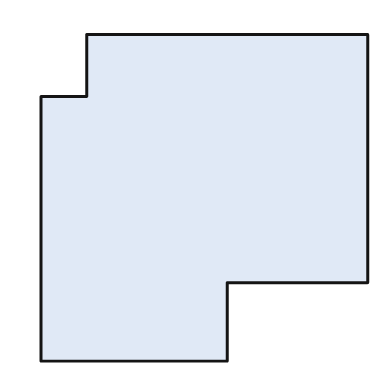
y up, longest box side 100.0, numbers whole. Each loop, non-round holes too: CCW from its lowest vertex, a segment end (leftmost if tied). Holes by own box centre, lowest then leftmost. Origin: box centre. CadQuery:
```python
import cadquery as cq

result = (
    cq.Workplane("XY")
    .moveTo(-50.0, -50.0)
    .lineTo(7.0, -50.0)
    .lineTo(7.0, -26.0)
    .lineTo(50.0, -26.0)
    .lineTo(50.0, 50.0)
    .lineTo(-36.0, 50.0)
    .lineTo(-36.0, 31.0)
    .lineTo(-50.0, 31.0)
    .close()
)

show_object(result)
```